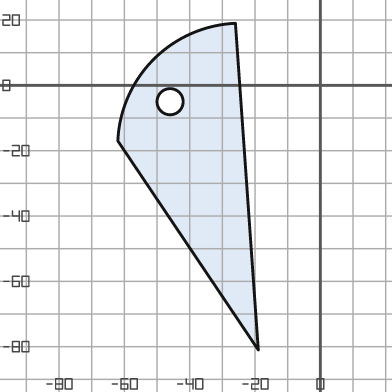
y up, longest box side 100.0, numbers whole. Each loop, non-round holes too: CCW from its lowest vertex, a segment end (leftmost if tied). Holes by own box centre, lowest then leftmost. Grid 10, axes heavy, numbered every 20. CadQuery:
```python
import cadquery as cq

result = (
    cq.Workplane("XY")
    .moveTo(-19.0, -81.0)
    .lineTo(-26.0, 19.0)
    .threePointArc((-51.0, 8.0), (-62.0, -17.0))
    .close()
    .moveTo(-46.0, -5.0)
    .circle(4.0)
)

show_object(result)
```